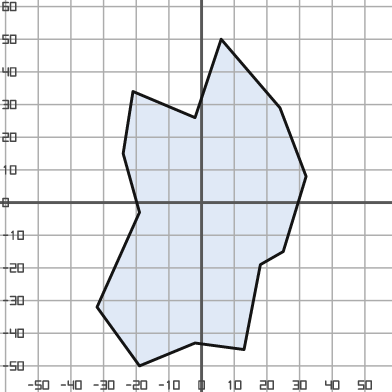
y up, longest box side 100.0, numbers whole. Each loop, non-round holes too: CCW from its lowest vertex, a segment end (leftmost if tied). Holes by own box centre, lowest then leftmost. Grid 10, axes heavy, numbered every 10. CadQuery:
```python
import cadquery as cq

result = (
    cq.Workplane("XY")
    .moveTo(-19.0, -50.0)
    .lineTo(-2.0, -43.0)
    .lineTo(13.0, -45.0)
    .lineTo(18.0, -19.0)
    .lineTo(25.0, -15.0)
    .lineTo(32.0, 8.0)
    .lineTo(24.0, 29.0)
    .lineTo(6.0, 50.0)
    .lineTo(-2.0, 26.0)
    .lineTo(-21.0, 34.0)
    .lineTo(-24.0, 15.0)
    .lineTo(-19.0, -3.0)
    .lineTo(-32.0, -32.0)
    .close()
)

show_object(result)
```